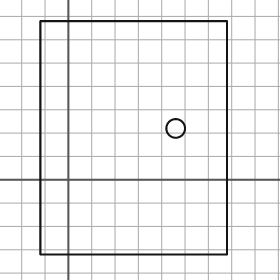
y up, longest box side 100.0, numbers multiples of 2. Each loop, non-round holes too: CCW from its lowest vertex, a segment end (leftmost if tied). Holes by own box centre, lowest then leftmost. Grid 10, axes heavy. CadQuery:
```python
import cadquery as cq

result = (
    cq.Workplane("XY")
    .moveTo(-12.0, -32.0)
    .lineTo(68.0, -32.0)
    .lineTo(68.0, 68.0)
    .lineTo(-12.0, 68.0)
    .close()
    .moveTo(46.0, 22.0)
    .circle(4.0)
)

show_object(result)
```